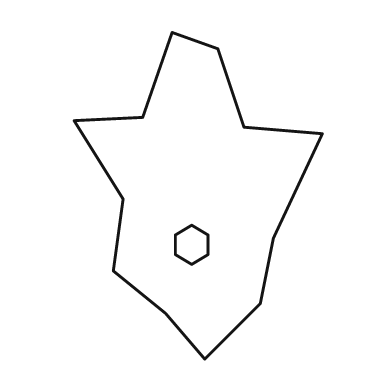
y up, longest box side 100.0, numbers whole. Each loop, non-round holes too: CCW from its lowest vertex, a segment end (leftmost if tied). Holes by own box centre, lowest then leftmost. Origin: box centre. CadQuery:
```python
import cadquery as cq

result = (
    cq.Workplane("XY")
    .moveTo(2.0, -50.0)
    .lineTo(19.0, -33.0)
    .lineTo(23.0, -13.0)
    .lineTo(38.0, 19.0)
    .lineTo(14.0, 21.0)
    .lineTo(6.0, 45.0)
    .lineTo(-8.0, 50.0)
    .lineTo(-17.0, 24.0)
    .lineTo(-38.0, 23.0)
    .lineTo(-23.0, -1.0)
    .lineTo(-26.0, -23.0)
    .lineTo(-10.0, -36.0)
    .close()
    .moveTo(-2.0, -21.0)
    .lineTo(3.0, -18.0)
    .lineTo(3.0, -12.0)
    .lineTo(-2.0, -9.0)
    .lineTo(-7.0, -12.0)
    .lineTo(-7.0, -18.0)
    .close()
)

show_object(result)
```